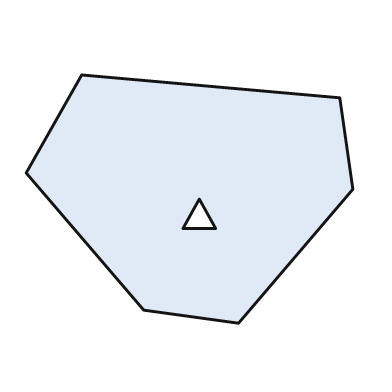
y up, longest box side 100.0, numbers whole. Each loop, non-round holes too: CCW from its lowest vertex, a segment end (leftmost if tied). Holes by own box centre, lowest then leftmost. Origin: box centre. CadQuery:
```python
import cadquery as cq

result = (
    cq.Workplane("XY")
    .moveTo(15.0, -38.0)
    .lineTo(50.0, 3.0)
    .lineTo(46.0, 31.0)
    .lineTo(-33.0, 38.0)
    .lineTo(-50.0, 8.0)
    .lineTo(-14.0, -34.0)
    .close()
    .moveTo(-2.0, -9.0)
    .lineTo(8.0, -9.0)
    .lineTo(3.0, 0.0)
    .close()
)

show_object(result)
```